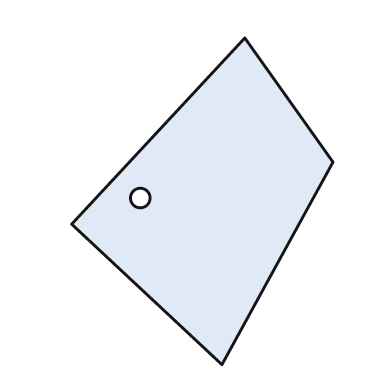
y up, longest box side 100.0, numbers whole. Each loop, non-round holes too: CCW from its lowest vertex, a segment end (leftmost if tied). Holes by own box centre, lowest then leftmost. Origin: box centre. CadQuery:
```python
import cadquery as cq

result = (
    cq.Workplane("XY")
    .moveTo(6.0, -50.0)
    .lineTo(40.0, 12.0)
    .lineTo(13.0, 50.0)
    .lineTo(-40.0, -7.0)
    .close()
    .moveTo(-19.0, 1.0)
    .circle(3.0)
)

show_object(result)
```